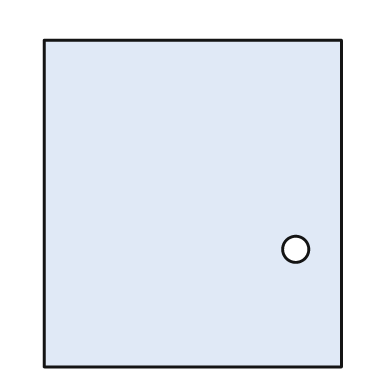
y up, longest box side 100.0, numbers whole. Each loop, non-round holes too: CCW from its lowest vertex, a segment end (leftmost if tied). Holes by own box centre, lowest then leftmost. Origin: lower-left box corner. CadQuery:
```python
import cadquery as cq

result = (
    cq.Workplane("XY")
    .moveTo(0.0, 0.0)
    .lineTo(91.0, 0.0)
    .lineTo(91.0, 100.0)
    .lineTo(0.0, 100.0)
    .close()
    .moveTo(77.0, 36.0)
    .circle(4.0)
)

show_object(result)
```